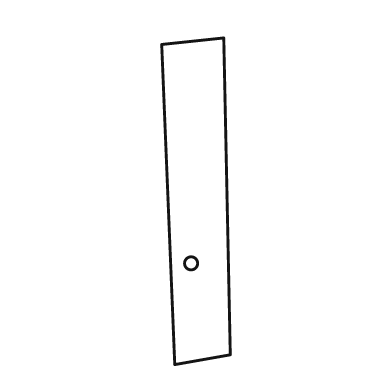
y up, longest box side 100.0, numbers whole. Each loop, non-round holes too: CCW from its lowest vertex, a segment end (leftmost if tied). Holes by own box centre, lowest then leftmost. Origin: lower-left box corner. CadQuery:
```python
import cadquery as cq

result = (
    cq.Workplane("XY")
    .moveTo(4.0, 0.0)
    .lineTo(21.0, 3.0)
    .lineTo(19.0, 100.0)
    .lineTo(0.0, 98.0)
    .close()
    .moveTo(9.0, 31.0)
    .circle(2.0)
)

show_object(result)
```